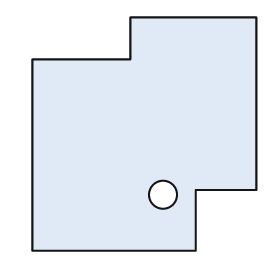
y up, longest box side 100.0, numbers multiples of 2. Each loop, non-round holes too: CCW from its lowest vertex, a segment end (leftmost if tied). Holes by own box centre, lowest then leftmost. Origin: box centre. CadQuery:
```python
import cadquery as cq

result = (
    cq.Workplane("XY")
    .moveTo(-48.0, -50.0)
    .lineTo(22.0, -50.0)
    .lineTo(22.0, -24.0)
    .lineTo(48.0, -24.0)
    .lineTo(48.0, 50.0)
    .lineTo(-6.0, 50.0)
    .lineTo(-6.0, 32.0)
    .lineTo(-48.0, 32.0)
    .close()
    .moveTo(8.0, -26.0)
    .circle(6.0)
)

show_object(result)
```